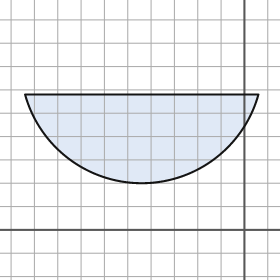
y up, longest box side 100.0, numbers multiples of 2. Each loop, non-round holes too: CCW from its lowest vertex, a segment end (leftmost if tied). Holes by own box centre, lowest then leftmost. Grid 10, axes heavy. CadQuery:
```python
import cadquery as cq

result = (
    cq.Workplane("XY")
    .moveTo(-94.0, 58.0)
    .threePointArc((-44.0, 20.0), (6.0, 58.0))
    .close()
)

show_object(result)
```